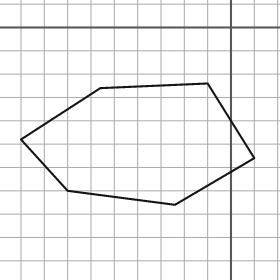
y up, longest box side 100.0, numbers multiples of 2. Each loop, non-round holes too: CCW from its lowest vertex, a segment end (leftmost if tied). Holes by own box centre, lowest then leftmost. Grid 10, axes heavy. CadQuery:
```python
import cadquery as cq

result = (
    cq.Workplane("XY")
    .moveTo(-24.0, -76.0)
    .lineTo(10.0, -56.0)
    .lineTo(-10.0, -24.0)
    .lineTo(-56.0, -26.0)
    .lineTo(-90.0, -48.0)
    .lineTo(-70.0, -70.0)
    .close()
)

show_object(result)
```